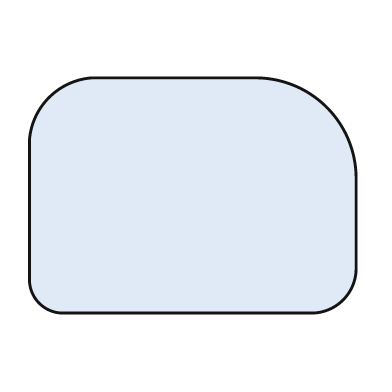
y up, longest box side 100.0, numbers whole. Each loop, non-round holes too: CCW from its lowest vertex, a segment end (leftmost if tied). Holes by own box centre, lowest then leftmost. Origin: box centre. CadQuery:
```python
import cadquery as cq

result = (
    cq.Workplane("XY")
    .moveTo(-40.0, -36.0)
    .lineTo(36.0, -36.0)
    .threePointArc((46.0, -32.0), (50.0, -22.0))
    .lineTo(50.0, 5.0)
    .threePointArc((41.0, 27.0), (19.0, 36.0))
    .lineTo(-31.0, 36.0)
    .threePointArc((-44.0, 30.0), (-50.0, 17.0))
    .lineTo(-50.0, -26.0)
    .threePointArc((-47.0, -33.0), (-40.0, -36.0))
    .close()
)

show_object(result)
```